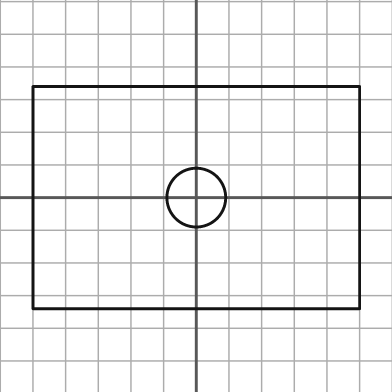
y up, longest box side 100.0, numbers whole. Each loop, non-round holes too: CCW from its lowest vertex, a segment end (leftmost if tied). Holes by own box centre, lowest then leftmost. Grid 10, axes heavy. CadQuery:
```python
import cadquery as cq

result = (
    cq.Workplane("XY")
    .moveTo(-50.0, -34.0)
    .lineTo(50.0, -34.0)
    .lineTo(50.0, 34.0)
    .lineTo(-50.0, 34.0)
    .close()
    .moveTo(0.0, 0.0)
    .circle(9.0)
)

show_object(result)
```